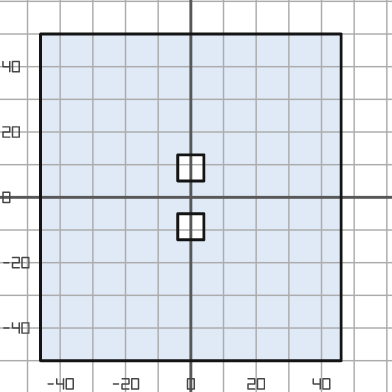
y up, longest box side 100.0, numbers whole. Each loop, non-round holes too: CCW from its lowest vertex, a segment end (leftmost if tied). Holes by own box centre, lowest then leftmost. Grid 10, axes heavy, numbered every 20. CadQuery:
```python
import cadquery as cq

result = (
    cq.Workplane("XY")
    .moveTo(-46.0, -50.0)
    .lineTo(46.0, -50.0)
    .lineTo(46.0, 50.0)
    .lineTo(-46.0, 50.0)
    .close()
    .moveTo(-4.0, -13.0)
    .lineTo(4.0, -13.0)
    .lineTo(4.0, -5.0)
    .lineTo(-4.0, -5.0)
    .close()
    .moveTo(-4.0, 5.0)
    .lineTo(4.0, 5.0)
    .lineTo(4.0, 13.0)
    .lineTo(-4.0, 13.0)
    .close()
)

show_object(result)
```